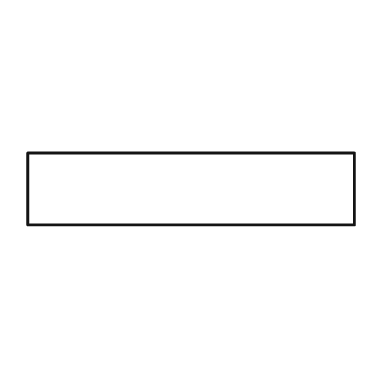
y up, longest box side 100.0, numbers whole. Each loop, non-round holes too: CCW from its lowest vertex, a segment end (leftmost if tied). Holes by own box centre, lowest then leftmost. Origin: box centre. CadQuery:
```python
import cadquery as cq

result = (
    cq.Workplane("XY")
    .moveTo(-50.0, -11.0)
    .lineTo(50.0, -11.0)
    .lineTo(50.0, 11.0)
    .lineTo(-50.0, 11.0)
    .close()
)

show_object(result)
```